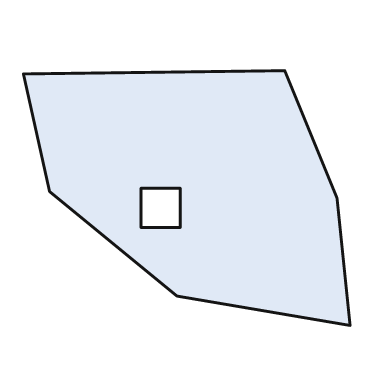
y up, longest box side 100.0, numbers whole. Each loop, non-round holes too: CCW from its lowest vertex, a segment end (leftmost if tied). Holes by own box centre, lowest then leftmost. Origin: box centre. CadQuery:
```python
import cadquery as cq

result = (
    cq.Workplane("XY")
    .moveTo(50.0, -39.0)
    .lineTo(46.0, 0.0)
    .lineTo(30.0, 39.0)
    .lineTo(-50.0, 38.0)
    .lineTo(-42.0, 2.0)
    .lineTo(-3.0, -30.0)
    .close()
    .moveTo(-14.0, -9.0)
    .lineTo(-2.0, -9.0)
    .lineTo(-2.0, 3.0)
    .lineTo(-14.0, 3.0)
    .close()
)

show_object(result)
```